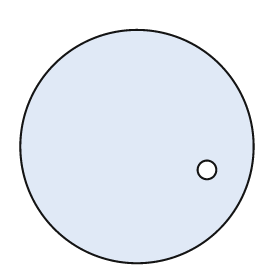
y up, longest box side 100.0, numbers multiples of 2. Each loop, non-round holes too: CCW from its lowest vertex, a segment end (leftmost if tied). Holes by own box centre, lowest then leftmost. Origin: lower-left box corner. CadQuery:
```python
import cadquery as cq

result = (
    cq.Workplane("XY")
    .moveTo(50.0, 50.0)
    .circle(50.0)
    .moveTo(80.0, 40.0)
    .circle(4.0)
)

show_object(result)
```